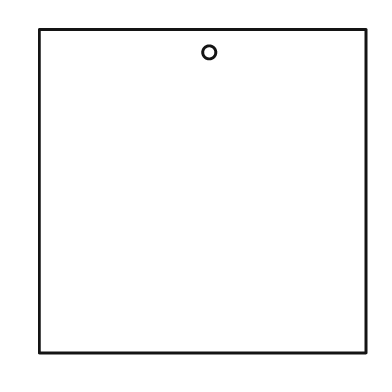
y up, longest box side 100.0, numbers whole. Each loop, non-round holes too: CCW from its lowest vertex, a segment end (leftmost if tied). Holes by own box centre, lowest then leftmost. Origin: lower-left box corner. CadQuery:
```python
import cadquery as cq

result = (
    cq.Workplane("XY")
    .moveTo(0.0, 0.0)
    .lineTo(100.0, 0.0)
    .lineTo(100.0, 99.0)
    .lineTo(0.0, 99.0)
    .close()
    .moveTo(52.0, 92.0)
    .circle(2.0)
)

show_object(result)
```